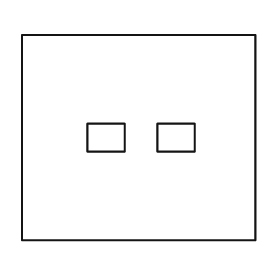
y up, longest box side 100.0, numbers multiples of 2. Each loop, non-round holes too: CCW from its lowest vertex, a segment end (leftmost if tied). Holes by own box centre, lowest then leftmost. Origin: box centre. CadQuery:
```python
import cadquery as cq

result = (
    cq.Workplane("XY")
    .moveTo(-50.0, -44.0)
    .lineTo(50.0, -44.0)
    .lineTo(50.0, 44.0)
    .lineTo(-50.0, 44.0)
    .close()
    .moveTo(-22.0, -6.0)
    .lineTo(-6.0, -6.0)
    .lineTo(-6.0, 6.0)
    .lineTo(-22.0, 6.0)
    .close()
    .moveTo(8.0, -6.0)
    .lineTo(24.0, -6.0)
    .lineTo(24.0, 6.0)
    .lineTo(8.0, 6.0)
    .close()
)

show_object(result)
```